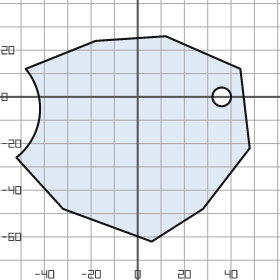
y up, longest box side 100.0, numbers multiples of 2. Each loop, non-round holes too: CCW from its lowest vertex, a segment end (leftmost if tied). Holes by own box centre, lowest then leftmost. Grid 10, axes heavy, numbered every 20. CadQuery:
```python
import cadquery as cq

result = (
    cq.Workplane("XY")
    .moveTo(6.0, -62.0)
    .lineTo(28.0, -48.0)
    .lineTo(48.0, -22.0)
    .lineTo(44.0, 12.0)
    .lineTo(12.0, 26.0)
    .lineTo(-18.0, 24.0)
    .lineTo(-48.0, 12.0)
    .threePointArc((-42.0, -8.0), (-52.0, -26.0))
    .lineTo(-32.0, -48.0)
    .close()
    .moveTo(36.0, 0.0)
    .circle(4.0)
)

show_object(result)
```